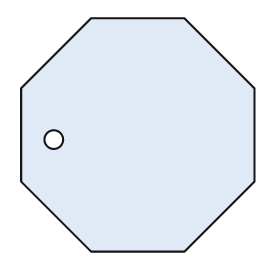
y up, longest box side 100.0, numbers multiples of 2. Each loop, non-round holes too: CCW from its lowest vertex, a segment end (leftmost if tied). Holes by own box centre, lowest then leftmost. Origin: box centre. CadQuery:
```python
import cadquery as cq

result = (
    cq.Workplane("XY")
    .moveTo(-20.0, -50.0)
    .lineTo(20.0, -50.0)
    .lineTo(50.0, -20.0)
    .lineTo(50.0, 20.0)
    .lineTo(20.0, 50.0)
    .lineTo(-20.0, 50.0)
    .lineTo(-50.0, 20.0)
    .lineTo(-50.0, -20.0)
    .close()
    .moveTo(-36.0, -2.0)
    .circle(4.0)
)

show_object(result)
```